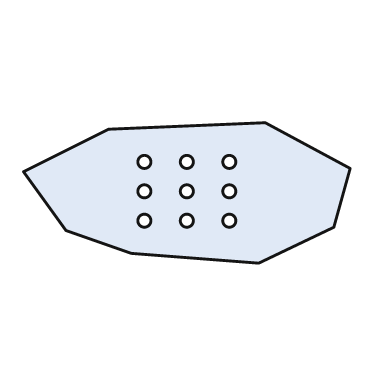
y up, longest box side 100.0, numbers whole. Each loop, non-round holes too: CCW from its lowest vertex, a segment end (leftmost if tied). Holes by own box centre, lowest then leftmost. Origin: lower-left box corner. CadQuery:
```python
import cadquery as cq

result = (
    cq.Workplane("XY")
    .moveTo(72.0, 0.0)
    .lineTo(95.0, 11.0)
    .lineTo(100.0, 29.0)
    .lineTo(74.0, 43.0)
    .lineTo(26.0, 41.0)
    .lineTo(0.0, 28.0)
    .lineTo(13.0, 10.0)
    .lineTo(33.0, 3.0)
    .close()
    .moveTo(37.0, 13.0)
    .circle(2.0)
    .moveTo(50.0, 13.0)
    .circle(2.0)
    .moveTo(63.0, 13.0)
    .circle(2.0)
    .moveTo(37.0, 22.0)
    .circle(2.0)
    .moveTo(50.0, 22.0)
    .circle(2.0)
    .moveTo(63.0, 22.0)
    .circle(2.0)
    .moveTo(37.0, 31.0)
    .circle(2.0)
    .moveTo(50.0, 31.0)
    .circle(2.0)
    .moveTo(63.0, 31.0)
    .circle(2.0)
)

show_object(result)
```